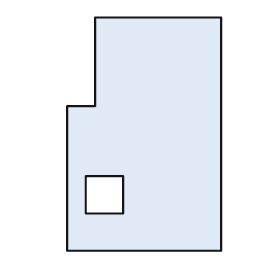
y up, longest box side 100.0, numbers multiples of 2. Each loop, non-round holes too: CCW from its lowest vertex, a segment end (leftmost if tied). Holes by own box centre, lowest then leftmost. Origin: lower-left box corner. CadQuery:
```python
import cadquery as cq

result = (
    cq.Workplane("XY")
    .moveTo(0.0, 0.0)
    .lineTo(66.0, 0.0)
    .lineTo(66.0, 100.0)
    .lineTo(12.0, 100.0)
    .lineTo(12.0, 62.0)
    .lineTo(0.0, 62.0)
    .close()
    .moveTo(8.0, 16.0)
    .lineTo(24.0, 16.0)
    .lineTo(24.0, 32.0)
    .lineTo(8.0, 32.0)
    .close()
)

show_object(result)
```